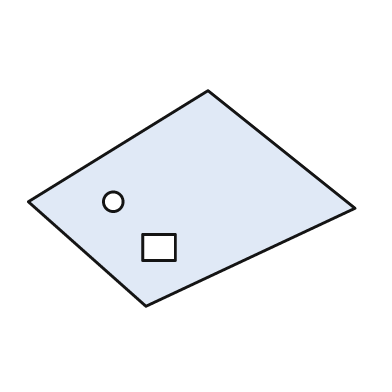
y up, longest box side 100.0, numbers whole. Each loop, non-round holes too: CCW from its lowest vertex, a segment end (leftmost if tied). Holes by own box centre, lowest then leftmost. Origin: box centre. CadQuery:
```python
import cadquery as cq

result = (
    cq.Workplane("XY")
    .moveTo(-14.0, -33.0)
    .lineTo(50.0, -3.0)
    .lineTo(5.0, 33.0)
    .lineTo(-50.0, -1.0)
    .close()
    .moveTo(-15.0, -19.0)
    .lineTo(-5.0, -19.0)
    .lineTo(-5.0, -11.0)
    .lineTo(-15.0, -11.0)
    .close()
    .moveTo(-24.0, -1.0)
    .circle(3.0)
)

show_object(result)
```